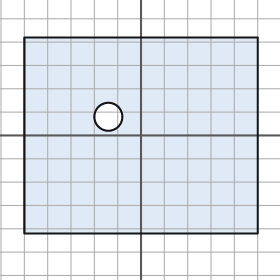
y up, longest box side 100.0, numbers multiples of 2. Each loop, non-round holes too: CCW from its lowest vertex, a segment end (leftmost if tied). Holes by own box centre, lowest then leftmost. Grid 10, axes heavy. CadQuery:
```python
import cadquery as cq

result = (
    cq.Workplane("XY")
    .moveTo(-50.0, -42.0)
    .lineTo(50.0, -42.0)
    .lineTo(50.0, 42.0)
    .lineTo(-50.0, 42.0)
    .close()
    .moveTo(-14.0, 8.0)
    .circle(6.0)
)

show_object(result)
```